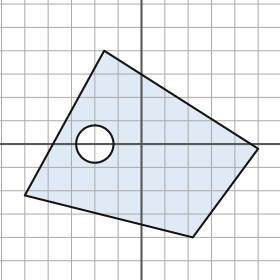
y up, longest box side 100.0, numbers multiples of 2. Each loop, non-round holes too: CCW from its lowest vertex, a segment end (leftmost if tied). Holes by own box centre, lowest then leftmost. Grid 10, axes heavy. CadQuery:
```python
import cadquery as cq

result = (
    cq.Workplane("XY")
    .moveTo(22.0, -40.0)
    .lineTo(50.0, -2.0)
    .lineTo(-16.0, 40.0)
    .lineTo(-50.0, -22.0)
    .close()
    .moveTo(-20.0, 0.0)
    .circle(8.0)
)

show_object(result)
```